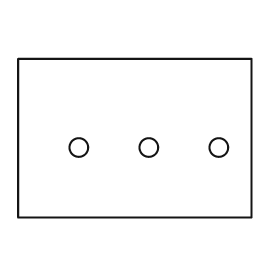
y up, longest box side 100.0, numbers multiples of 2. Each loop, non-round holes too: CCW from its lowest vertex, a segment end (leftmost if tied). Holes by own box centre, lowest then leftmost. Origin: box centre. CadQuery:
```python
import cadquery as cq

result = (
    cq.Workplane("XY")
    .moveTo(-50.0, -34.0)
    .lineTo(50.0, -34.0)
    .lineTo(50.0, 34.0)
    .lineTo(-50.0, 34.0)
    .close()
    .moveTo(-24.0, -4.0)
    .circle(4.0)
    .moveTo(6.0, -4.0)
    .circle(4.0)
    .moveTo(36.0, -4.0)
    .circle(4.0)
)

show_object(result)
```